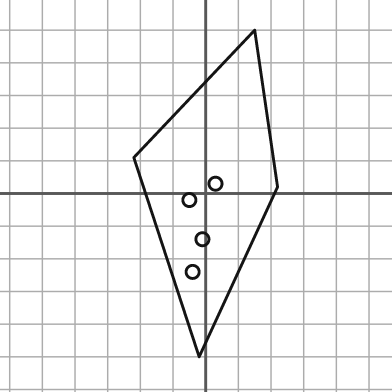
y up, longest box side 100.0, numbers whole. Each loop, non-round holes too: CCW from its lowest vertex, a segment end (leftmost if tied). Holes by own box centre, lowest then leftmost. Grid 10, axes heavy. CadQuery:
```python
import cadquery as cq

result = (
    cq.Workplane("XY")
    .moveTo(-2.0, -50.0)
    .lineTo(22.0, 2.0)
    .lineTo(15.0, 50.0)
    .lineTo(-22.0, 11.0)
    .close()
    .moveTo(-4.0, -24.0)
    .circle(2.0)
    .moveTo(-1.0, -14.0)
    .circle(2.0)
    .moveTo(-5.0, -2.0)
    .circle(2.0)
    .moveTo(3.0, 3.0)
    .circle(2.0)
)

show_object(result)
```